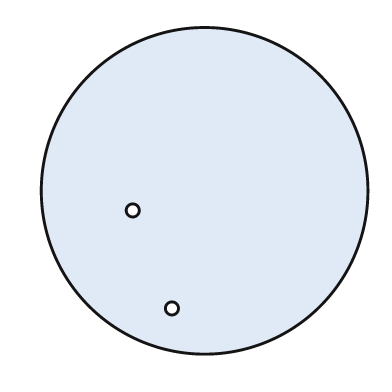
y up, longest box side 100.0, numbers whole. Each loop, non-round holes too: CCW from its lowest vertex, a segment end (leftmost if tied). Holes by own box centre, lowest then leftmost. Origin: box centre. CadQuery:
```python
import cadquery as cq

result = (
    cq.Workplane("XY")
    .moveTo(0.0, 0.0)
    .circle(50.0)
    .moveTo(-10.0, -36.0)
    .circle(2.0)
    .moveTo(-22.0, -6.0)
    .circle(2.0)
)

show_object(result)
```